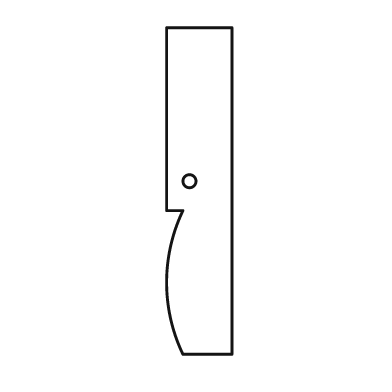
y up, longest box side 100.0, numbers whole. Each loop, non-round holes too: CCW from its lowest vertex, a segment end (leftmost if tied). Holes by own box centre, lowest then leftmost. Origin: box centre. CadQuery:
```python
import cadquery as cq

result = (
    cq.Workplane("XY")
    .moveTo(-5.0, -50.0)
    .lineTo(10.0, -50.0)
    .lineTo(10.0, 50.0)
    .lineTo(-10.0, 50.0)
    .lineTo(-10.0, -6.0)
    .lineTo(-5.0, -6.0)
    .threePointArc((-10.0, -28.0), (-5.0, -50.0))
    .close()
    .moveTo(-3.0, 3.0)
    .circle(2.0)
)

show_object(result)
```